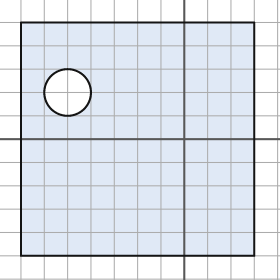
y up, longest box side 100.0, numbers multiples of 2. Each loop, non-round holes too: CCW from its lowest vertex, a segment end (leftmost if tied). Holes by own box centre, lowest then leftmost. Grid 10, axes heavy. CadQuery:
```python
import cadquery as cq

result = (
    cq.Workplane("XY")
    .moveTo(-70.0, -50.0)
    .lineTo(30.0, -50.0)
    .lineTo(30.0, 50.0)
    .lineTo(-70.0, 50.0)
    .close()
    .moveTo(-50.0, 20.0)
    .circle(10.0)
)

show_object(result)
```